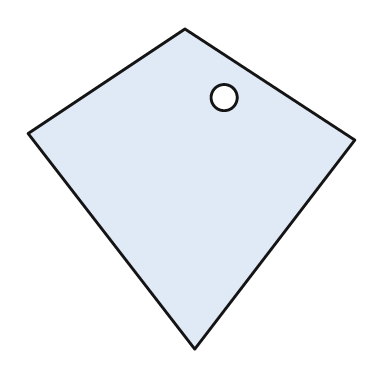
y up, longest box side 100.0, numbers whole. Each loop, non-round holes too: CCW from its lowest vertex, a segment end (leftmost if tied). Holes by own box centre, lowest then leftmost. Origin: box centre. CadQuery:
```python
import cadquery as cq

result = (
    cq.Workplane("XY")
    .moveTo(1.0, -49.0)
    .lineTo(50.0, 15.0)
    .lineTo(-2.0, 49.0)
    .lineTo(-50.0, 17.0)
    .close()
    .moveTo(10.0, 28.0)
    .circle(4.0)
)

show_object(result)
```